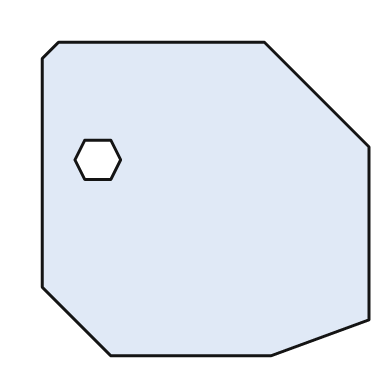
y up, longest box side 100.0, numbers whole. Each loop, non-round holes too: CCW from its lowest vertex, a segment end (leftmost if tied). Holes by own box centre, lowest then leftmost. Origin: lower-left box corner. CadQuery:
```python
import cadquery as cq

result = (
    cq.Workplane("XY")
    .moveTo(21.0, 0.0)
    .lineTo(70.0, 0.0)
    .lineTo(100.0, 11.0)
    .lineTo(100.0, 64.0)
    .lineTo(68.0, 96.0)
    .lineTo(5.0, 96.0)
    .lineTo(0.0, 91.0)
    .lineTo(0.0, 21.0)
    .close()
    .moveTo(13.0, 54.0)
    .lineTo(21.0, 54.0)
    .lineTo(24.0, 60.0)
    .lineTo(21.0, 66.0)
    .lineTo(13.0, 66.0)
    .lineTo(10.0, 60.0)
    .close()
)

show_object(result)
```